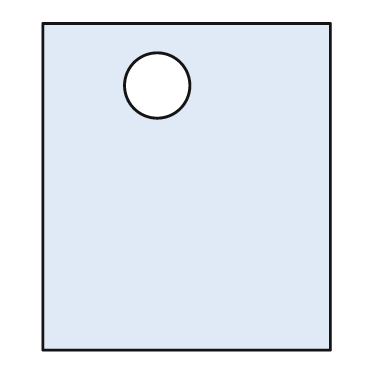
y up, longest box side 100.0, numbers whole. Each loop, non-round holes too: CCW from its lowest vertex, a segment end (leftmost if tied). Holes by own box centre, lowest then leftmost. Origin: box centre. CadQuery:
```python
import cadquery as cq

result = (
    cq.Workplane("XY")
    .moveTo(-44.0, -50.0)
    .lineTo(44.0, -50.0)
    .lineTo(44.0, 50.0)
    .lineTo(-44.0, 50.0)
    .close()
    .moveTo(-9.0, 31.0)
    .circle(10.0)
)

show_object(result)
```